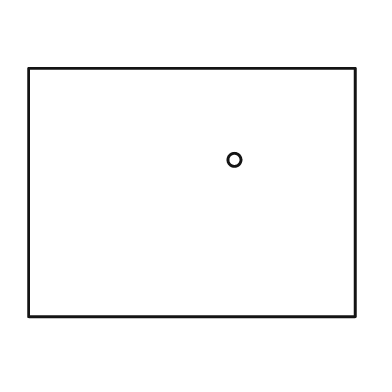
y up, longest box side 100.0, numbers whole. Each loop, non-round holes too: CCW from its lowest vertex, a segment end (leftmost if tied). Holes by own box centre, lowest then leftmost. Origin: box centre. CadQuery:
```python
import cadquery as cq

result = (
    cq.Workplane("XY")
    .moveTo(-50.0, -38.0)
    .lineTo(50.0, -38.0)
    .lineTo(50.0, 38.0)
    .lineTo(-50.0, 38.0)
    .close()
    .moveTo(13.0, 10.0)
    .circle(2.0)
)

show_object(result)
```